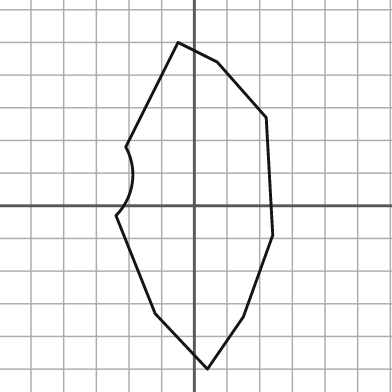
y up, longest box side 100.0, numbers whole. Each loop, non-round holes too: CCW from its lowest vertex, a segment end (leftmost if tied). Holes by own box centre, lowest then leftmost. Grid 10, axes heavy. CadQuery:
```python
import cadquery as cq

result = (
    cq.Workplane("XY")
    .moveTo(4.0, -50.0)
    .lineTo(15.0, -34.0)
    .lineTo(24.0, -9.0)
    .lineTo(22.0, 27.0)
    .lineTo(7.0, 44.0)
    .lineTo(-5.0, 50.0)
    .lineTo(-21.0, 18.0)
    .threePointArc((-19.0, 7.0), (-24.0, -3.0))
    .lineTo(-12.0, -33.0)
    .close()
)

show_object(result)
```